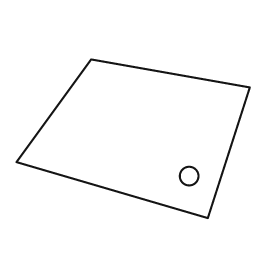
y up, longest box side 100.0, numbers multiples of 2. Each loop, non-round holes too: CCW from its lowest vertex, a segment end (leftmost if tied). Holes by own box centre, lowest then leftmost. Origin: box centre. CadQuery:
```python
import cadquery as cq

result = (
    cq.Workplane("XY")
    .moveTo(32.0, -34.0)
    .lineTo(50.0, 22.0)
    .lineTo(-18.0, 34.0)
    .lineTo(-50.0, -10.0)
    .close()
    .moveTo(24.0, -16.0)
    .circle(4.0)
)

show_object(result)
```